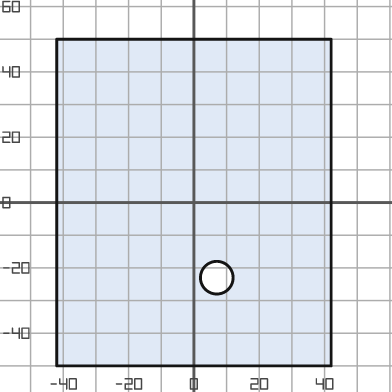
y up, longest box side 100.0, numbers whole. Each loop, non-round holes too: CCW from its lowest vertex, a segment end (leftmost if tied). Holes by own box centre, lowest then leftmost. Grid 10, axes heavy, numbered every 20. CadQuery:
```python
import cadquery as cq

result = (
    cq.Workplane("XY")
    .moveTo(-42.0, -50.0)
    .lineTo(42.0, -50.0)
    .lineTo(42.0, 50.0)
    .lineTo(-42.0, 50.0)
    .close()
    .moveTo(7.0, -23.0)
    .circle(5.0)
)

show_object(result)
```